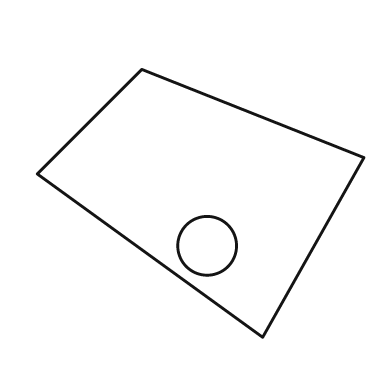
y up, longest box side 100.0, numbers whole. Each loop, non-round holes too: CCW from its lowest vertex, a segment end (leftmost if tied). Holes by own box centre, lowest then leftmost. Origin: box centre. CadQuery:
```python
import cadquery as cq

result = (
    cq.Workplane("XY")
    .moveTo(19.0, -41.0)
    .lineTo(50.0, 14.0)
    .lineTo(-18.0, 41.0)
    .lineTo(-50.0, 9.0)
    .close()
    .moveTo(2.0, -13.0)
    .circle(9.0)
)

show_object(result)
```